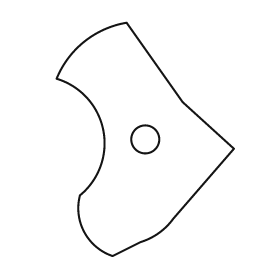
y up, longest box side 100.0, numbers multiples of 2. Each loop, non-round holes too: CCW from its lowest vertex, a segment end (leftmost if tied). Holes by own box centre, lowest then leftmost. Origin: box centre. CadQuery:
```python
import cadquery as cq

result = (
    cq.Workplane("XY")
    .moveTo(-14.0, -50.0)
    .lineTo(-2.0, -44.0)
    .threePointArc((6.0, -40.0), (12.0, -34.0))
    .lineTo(38.0, -4.0)
    .lineTo(16.0, 16.0)
    .lineTo(-8.0, 50.0)
    .threePointArc((-26.0, 42.0), (-38.0, 26.0))
    .threePointArc((-18.0, 4.0), (-28.0, -24.0))
    .threePointArc((-26.0, -40.0), (-14.0, -50.0))
    .close()
    .moveTo(0.0, 0.0)
    .circle(6.0)
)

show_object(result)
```